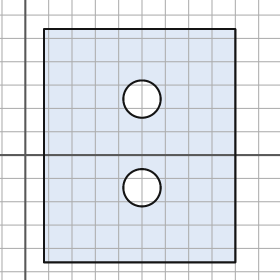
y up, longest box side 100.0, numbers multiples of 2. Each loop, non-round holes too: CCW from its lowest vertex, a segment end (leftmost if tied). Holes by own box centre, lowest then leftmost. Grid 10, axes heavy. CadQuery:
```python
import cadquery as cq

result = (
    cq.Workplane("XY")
    .moveTo(8.0, -46.0)
    .lineTo(90.0, -46.0)
    .lineTo(90.0, 54.0)
    .lineTo(8.0, 54.0)
    .close()
    .moveTo(50.0, -14.0)
    .circle(8.0)
    .moveTo(50.0, 24.0)
    .circle(8.0)
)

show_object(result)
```